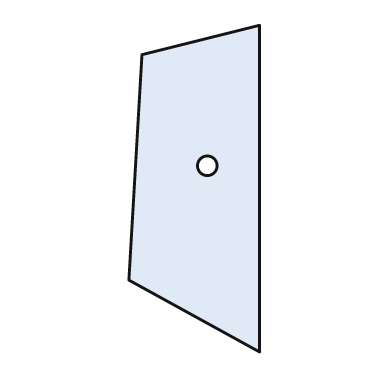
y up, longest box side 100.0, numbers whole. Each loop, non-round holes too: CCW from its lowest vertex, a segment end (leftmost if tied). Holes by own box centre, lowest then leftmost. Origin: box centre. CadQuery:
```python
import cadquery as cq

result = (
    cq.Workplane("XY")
    .moveTo(20.0, -50.0)
    .lineTo(20.0, 50.0)
    .lineTo(-16.0, 41.0)
    .lineTo(-20.0, -28.0)
    .close()
    .moveTo(4.0, 7.0)
    .circle(3.0)
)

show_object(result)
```